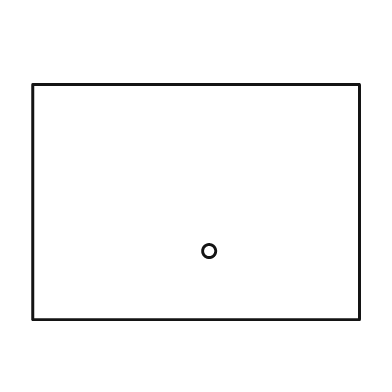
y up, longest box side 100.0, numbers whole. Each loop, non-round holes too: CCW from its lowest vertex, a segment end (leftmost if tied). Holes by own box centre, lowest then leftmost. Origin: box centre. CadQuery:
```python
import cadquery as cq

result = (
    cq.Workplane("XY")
    .moveTo(-50.0, -36.0)
    .lineTo(50.0, -36.0)
    .lineTo(50.0, 36.0)
    .lineTo(-50.0, 36.0)
    .close()
    .moveTo(4.0, -15.0)
    .circle(2.0)
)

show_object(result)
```